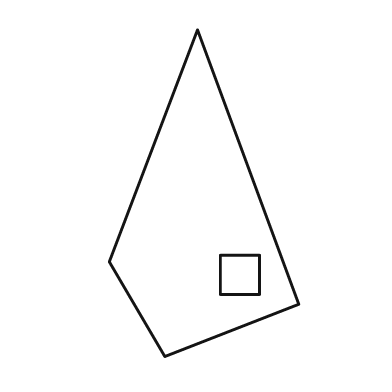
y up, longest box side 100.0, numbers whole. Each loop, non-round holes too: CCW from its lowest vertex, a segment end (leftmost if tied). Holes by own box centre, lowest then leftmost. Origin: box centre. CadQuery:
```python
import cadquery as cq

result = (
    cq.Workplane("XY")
    .moveTo(-12.0, -50.0)
    .lineTo(29.0, -34.0)
    .lineTo(-2.0, 50.0)
    .lineTo(-29.0, -21.0)
    .close()
    .moveTo(5.0, -31.0)
    .lineTo(17.0, -31.0)
    .lineTo(17.0, -19.0)
    .lineTo(5.0, -19.0)
    .close()
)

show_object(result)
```